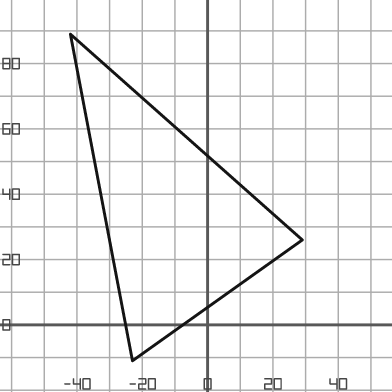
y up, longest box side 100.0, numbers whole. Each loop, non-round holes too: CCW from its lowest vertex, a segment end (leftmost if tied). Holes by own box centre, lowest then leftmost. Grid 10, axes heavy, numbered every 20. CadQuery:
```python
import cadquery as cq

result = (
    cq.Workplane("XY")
    .moveTo(-23.0, -11.0)
    .lineTo(29.0, 26.0)
    .lineTo(-42.0, 89.0)
    .close()
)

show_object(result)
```